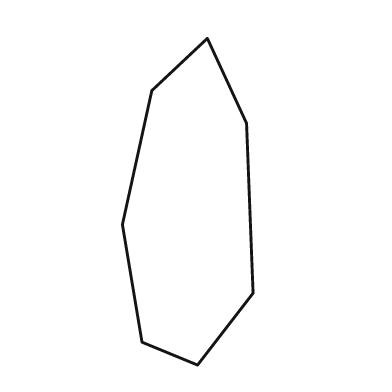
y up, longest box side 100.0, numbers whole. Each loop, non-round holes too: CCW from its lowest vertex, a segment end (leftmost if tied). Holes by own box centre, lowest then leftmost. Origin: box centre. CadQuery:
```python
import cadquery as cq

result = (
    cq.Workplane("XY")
    .moveTo(3.0, -50.0)
    .lineTo(20.0, -28.0)
    .lineTo(18.0, 24.0)
    .lineTo(6.0, 50.0)
    .lineTo(-11.0, 34.0)
    .lineTo(-20.0, -7.0)
    .lineTo(-14.0, -43.0)
    .close()
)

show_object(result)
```